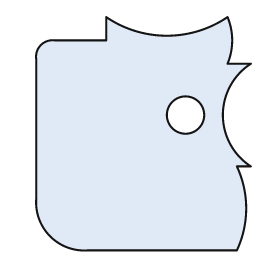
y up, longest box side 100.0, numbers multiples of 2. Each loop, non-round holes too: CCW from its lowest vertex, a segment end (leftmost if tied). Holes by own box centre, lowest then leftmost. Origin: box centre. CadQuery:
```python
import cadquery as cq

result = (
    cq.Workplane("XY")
    .moveTo(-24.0, -50.0)
    .lineTo(40.0, -50.0)
    .threePointArc((44.0, -32.0), (40.0, -14.0))
    .lineTo(46.0, -14.0)
    .threePointArc((34.0, 8.0), (46.0, 30.0))
    .lineTo(36.0, 30.0)
    .threePointArc((38.0, 40.0), (36.0, 50.0))
    .threePointArc((10.0, 42.0), (-16.0, 50.0))
    .lineTo(-16.0, 40.0)
    .lineTo(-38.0, 40.0)
    .threePointArc((-44.0, 38.0), (-46.0, 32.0))
    .lineTo(-46.0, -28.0)
    .threePointArc((-40.0, -44.0), (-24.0, -50.0))
    .close()
    .moveTo(18.0, 8.0)
    .circle(8.0)
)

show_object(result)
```